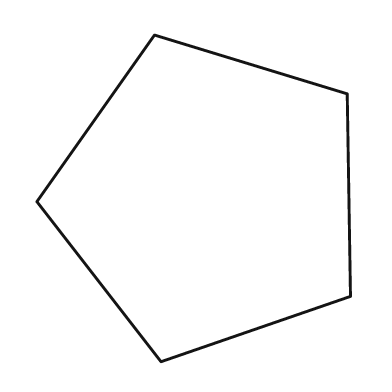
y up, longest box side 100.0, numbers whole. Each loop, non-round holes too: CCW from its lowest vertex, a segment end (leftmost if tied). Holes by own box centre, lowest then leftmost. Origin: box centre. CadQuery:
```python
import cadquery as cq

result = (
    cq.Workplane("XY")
    .moveTo(-10.0, -50.0)
    .lineTo(48.0, -30.0)
    .lineTo(47.0, 32.0)
    .lineTo(-12.0, 50.0)
    .lineTo(-48.0, -1.0)
    .close()
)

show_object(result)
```